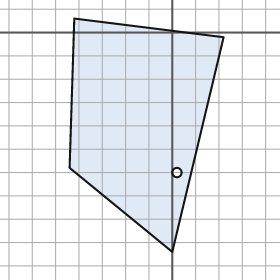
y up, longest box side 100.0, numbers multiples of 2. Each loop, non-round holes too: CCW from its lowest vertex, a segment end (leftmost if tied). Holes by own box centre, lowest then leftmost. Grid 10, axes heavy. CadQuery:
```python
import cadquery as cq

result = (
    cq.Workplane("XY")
    .moveTo(0.0, -94.0)
    .lineTo(22.0, -2.0)
    .lineTo(-42.0, 6.0)
    .lineTo(-44.0, -58.0)
    .close()
    .moveTo(2.0, -60.0)
    .circle(2.0)
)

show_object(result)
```